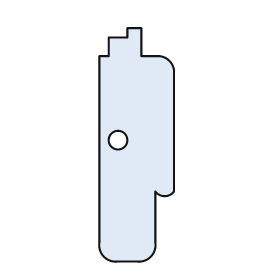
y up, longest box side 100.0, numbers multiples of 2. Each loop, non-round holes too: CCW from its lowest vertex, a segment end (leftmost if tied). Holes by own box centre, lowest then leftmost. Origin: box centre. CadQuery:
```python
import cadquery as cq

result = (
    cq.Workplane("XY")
    .moveTo(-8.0, -50.0)
    .lineTo(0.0, -50.0)
    .threePointArc((6.0, -48.0), (8.0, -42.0))
    .lineTo(8.0, -20.0)
    .threePointArc((12.0, -22.0), (16.0, -20.0))
    .lineTo(16.0, 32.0)
    .threePointArc((14.0, 36.0), (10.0, 38.0))
    .lineTo(2.0, 38.0)
    .lineTo(2.0, 50.0)
    .lineTo(-4.0, 50.0)
    .lineTo(-4.0, 46.0)
    .lineTo(-12.0, 46.0)
    .lineTo(-12.0, 38.0)
    .lineTo(-16.0, 38.0)
    .lineTo(-16.0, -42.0)
    .threePointArc((-14.0, -48.0), (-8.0, -50.0))
    .close()
    .moveTo(-8.0, 2.0)
    .circle(4.0)
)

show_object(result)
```